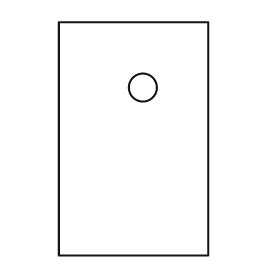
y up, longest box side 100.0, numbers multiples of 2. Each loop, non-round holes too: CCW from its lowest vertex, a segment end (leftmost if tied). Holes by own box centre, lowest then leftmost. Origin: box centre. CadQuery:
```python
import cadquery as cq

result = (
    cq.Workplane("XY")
    .moveTo(-32.0, -50.0)
    .lineTo(32.0, -50.0)
    .lineTo(32.0, 50.0)
    .lineTo(-32.0, 50.0)
    .close()
    .moveTo(4.0, 22.0)
    .circle(6.0)
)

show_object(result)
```